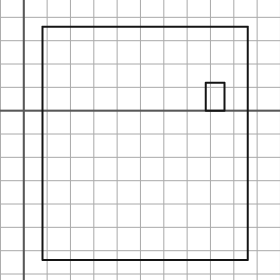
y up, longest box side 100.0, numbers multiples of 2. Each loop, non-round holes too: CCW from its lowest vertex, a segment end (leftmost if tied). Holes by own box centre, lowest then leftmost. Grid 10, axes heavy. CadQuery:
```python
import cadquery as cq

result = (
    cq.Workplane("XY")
    .moveTo(8.0, -64.0)
    .lineTo(96.0, -64.0)
    .lineTo(96.0, 36.0)
    .lineTo(8.0, 36.0)
    .close()
    .moveTo(78.0, 0.0)
    .lineTo(86.0, 0.0)
    .lineTo(86.0, 12.0)
    .lineTo(78.0, 12.0)
    .close()
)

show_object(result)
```